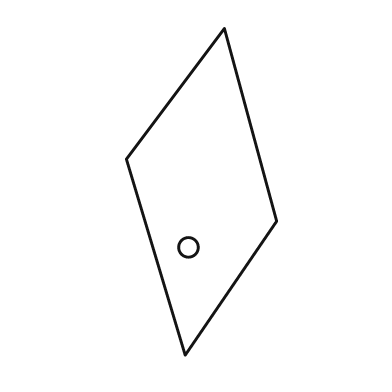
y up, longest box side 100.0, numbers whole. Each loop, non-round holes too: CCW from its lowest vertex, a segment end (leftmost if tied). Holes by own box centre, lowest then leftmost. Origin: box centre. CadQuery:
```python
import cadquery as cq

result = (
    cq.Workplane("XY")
    .moveTo(-5.0, -50.0)
    .lineTo(23.0, -9.0)
    .lineTo(7.0, 50.0)
    .lineTo(-23.0, 10.0)
    .close()
    .moveTo(-4.0, -17.0)
    .circle(3.0)
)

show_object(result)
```